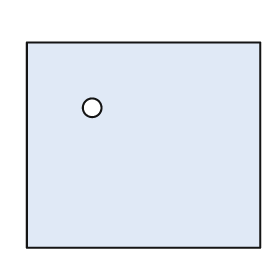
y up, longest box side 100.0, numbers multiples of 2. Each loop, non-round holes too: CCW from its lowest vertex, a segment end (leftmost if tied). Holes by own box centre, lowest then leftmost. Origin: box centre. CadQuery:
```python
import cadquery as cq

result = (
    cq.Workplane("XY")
    .moveTo(-50.0, -44.0)
    .lineTo(50.0, -44.0)
    .lineTo(50.0, 44.0)
    .lineTo(-50.0, 44.0)
    .close()
    .moveTo(-22.0, 16.0)
    .circle(4.0)
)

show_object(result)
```